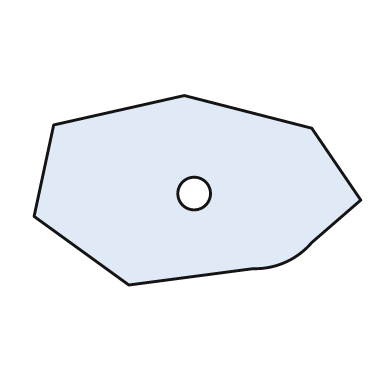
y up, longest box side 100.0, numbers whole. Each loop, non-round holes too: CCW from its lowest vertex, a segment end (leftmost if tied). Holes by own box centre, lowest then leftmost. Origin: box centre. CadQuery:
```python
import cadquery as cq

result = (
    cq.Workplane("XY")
    .moveTo(-21.0, -29.0)
    .lineTo(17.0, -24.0)
    .threePointArc((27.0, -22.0), (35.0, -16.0))
    .lineTo(50.0, -3.0)
    .lineTo(35.0, 19.0)
    .lineTo(-4.0, 29.0)
    .lineTo(-44.0, 20.0)
    .lineTo(-50.0, -8.0)
    .close()
    .moveTo(-1.0, -1.0)
    .circle(5.0)
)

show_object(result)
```